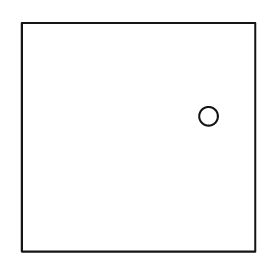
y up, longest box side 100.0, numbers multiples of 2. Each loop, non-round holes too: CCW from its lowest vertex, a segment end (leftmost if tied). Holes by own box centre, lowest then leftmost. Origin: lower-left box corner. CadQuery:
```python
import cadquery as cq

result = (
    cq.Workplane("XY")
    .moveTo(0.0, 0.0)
    .lineTo(100.0, 0.0)
    .lineTo(100.0, 98.0)
    .lineTo(0.0, 98.0)
    .close()
    .moveTo(80.0, 58.0)
    .circle(4.0)
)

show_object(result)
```